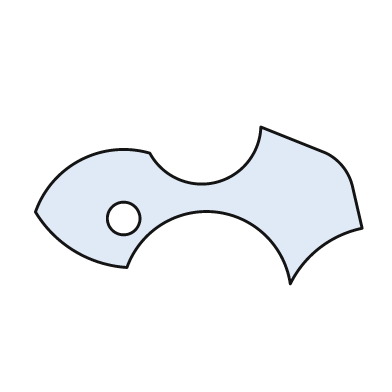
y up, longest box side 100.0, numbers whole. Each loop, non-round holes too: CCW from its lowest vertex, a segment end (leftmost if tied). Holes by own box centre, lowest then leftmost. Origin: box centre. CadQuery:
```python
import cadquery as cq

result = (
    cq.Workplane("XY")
    .moveTo(28.0, -24.0)
    .threePointArc((37.0, -13.0), (50.0, -7.0))
    .lineTo(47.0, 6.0)
    .threePointArc((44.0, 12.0), (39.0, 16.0))
    .lineTo(19.0, 24.0)
    .threePointArc((5.0, 7.0), (-15.0, 16.0))
    .threePointArc((-36.0, 14.0), (-50.0, -2.0))
    .threePointArc((-38.0, -14.0), (-22.0, -19.0))
    .threePointArc((5.0, -2.0), (28.0, -24.0))
    .close()
    .moveTo(-23.0, -4.0)
    .circle(5.0)
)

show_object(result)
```